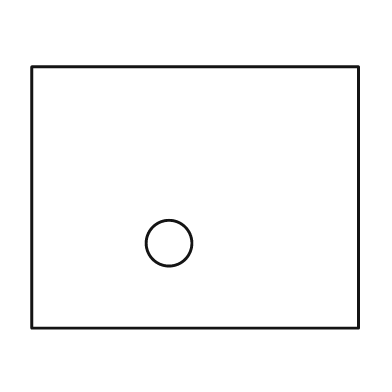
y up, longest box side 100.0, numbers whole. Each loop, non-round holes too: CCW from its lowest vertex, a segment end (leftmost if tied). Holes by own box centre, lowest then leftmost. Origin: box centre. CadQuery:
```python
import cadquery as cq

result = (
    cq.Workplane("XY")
    .moveTo(-50.0, -40.0)
    .lineTo(50.0, -40.0)
    .lineTo(50.0, 40.0)
    .lineTo(-50.0, 40.0)
    .close()
    .moveTo(-8.0, -14.0)
    .circle(7.0)
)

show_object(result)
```